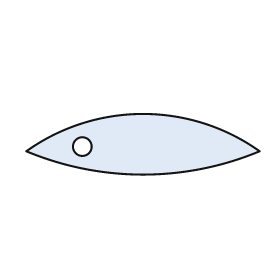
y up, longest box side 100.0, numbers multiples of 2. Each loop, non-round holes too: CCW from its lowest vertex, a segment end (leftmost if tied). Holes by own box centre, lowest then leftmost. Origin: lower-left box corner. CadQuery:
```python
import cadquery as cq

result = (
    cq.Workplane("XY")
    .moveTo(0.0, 10.0)
    .threePointArc((50.0, 0.0), (100.0, 10.0))
    .threePointArc((50.0, 26.0), (0.0, 10.0))
    .close()
    .moveTo(24.0, 12.0)
    .circle(4.0)
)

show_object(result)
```